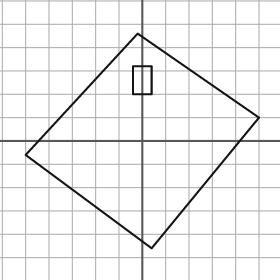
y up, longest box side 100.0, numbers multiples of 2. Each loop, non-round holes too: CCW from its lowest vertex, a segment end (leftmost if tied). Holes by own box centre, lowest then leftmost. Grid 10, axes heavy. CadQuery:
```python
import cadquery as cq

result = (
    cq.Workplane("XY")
    .moveTo(4.0, -46.0)
    .lineTo(50.0, 10.0)
    .lineTo(-2.0, 46.0)
    .lineTo(-50.0, -6.0)
    .close()
    .moveTo(-4.0, 20.0)
    .lineTo(4.0, 20.0)
    .lineTo(4.0, 32.0)
    .lineTo(-4.0, 32.0)
    .close()
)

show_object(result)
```